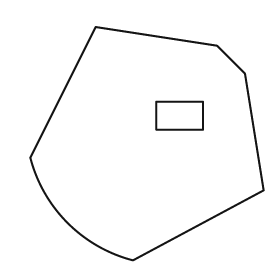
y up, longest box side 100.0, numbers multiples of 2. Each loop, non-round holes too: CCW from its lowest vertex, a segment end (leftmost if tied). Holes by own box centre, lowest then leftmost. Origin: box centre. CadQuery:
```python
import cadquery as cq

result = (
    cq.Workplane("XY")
    .moveTo(-6.0, -50.0)
    .lineTo(50.0, -20.0)
    .lineTo(42.0, 30.0)
    .lineTo(30.0, 42.0)
    .lineTo(-22.0, 50.0)
    .lineTo(-50.0, -6.0)
    .threePointArc((-34.0, -34.0), (-6.0, -50.0))
    .close()
    .moveTo(4.0, 6.0)
    .lineTo(24.0, 6.0)
    .lineTo(24.0, 18.0)
    .lineTo(4.0, 18.0)
    .close()
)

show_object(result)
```